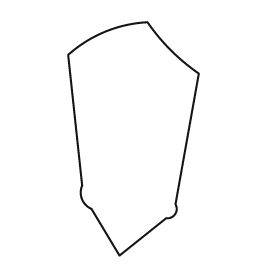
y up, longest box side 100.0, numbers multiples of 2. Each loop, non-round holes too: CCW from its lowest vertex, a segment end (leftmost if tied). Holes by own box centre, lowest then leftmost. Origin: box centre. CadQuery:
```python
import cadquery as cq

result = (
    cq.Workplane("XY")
    .moveTo(-6.0, -50.0)
    .lineTo(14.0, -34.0)
    .threePointArc((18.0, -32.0), (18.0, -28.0))
    .lineTo(28.0, 28.0)
    .threePointArc((16.0, 38.0), (6.0, 50.0))
    .threePointArc((-12.0, 46.0), (-28.0, 36.0))
    .lineTo(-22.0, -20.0)
    .threePointArc((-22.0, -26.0), (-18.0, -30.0))
    .close()
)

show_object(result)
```